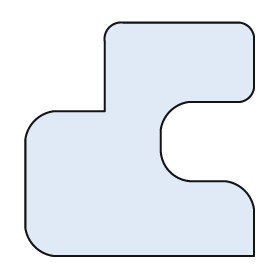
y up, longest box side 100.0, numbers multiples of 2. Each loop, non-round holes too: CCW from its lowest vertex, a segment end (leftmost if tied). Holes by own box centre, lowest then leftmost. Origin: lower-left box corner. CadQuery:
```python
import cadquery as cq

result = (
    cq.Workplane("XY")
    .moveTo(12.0, 0.0)
    .lineTo(98.0, 0.0)
    .lineTo(98.0, 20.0)
    .threePointArc((94.0, 28.0), (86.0, 32.0))
    .lineTo(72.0, 32.0)
    .threePointArc((62.0, 36.0), (58.0, 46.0))
    .lineTo(58.0, 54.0)
    .threePointArc((62.0, 62.0), (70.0, 66.0))
    .lineTo(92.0, 66.0)
    .threePointArc((96.0, 68.0), (98.0, 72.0))
    .lineTo(98.0, 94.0)
    .threePointArc((96.0, 98.0), (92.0, 100.0))
    .lineTo(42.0, 100.0)
    .threePointArc((36.0, 98.0), (34.0, 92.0))
    .lineTo(34.0, 62.0)
    .lineTo(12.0, 62.0)
    .threePointArc((4.0, 58.0), (0.0, 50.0))
    .lineTo(0.0, 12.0)
    .threePointArc((4.0, 4.0), (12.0, 0.0))
    .close()
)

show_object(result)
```